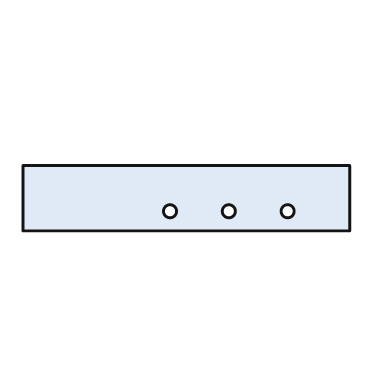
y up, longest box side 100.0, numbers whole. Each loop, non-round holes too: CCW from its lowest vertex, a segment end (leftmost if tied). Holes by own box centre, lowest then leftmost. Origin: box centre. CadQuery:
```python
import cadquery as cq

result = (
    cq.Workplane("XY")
    .moveTo(-50.0, -10.0)
    .lineTo(50.0, -10.0)
    .lineTo(50.0, 10.0)
    .lineTo(-50.0, 10.0)
    .close()
    .moveTo(-5.0, -4.0)
    .circle(2.0)
    .moveTo(13.0, -4.0)
    .circle(2.0)
    .moveTo(31.0, -4.0)
    .circle(2.0)
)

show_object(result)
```